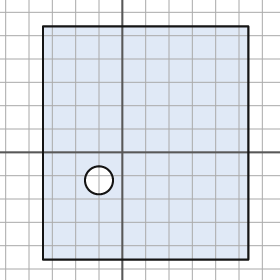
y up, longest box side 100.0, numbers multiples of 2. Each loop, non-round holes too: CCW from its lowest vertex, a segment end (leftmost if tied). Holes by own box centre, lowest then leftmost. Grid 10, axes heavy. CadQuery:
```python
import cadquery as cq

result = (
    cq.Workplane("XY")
    .moveTo(-34.0, -46.0)
    .lineTo(54.0, -46.0)
    .lineTo(54.0, 54.0)
    .lineTo(-34.0, 54.0)
    .close()
    .moveTo(-10.0, -12.0)
    .circle(6.0)
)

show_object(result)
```